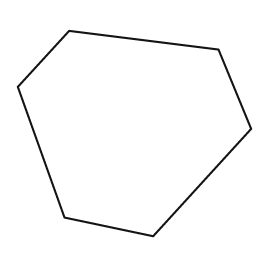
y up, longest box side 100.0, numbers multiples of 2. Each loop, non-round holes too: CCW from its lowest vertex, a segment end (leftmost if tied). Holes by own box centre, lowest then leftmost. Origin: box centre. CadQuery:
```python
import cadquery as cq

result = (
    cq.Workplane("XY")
    .moveTo(8.0, -44.0)
    .lineTo(50.0, 2.0)
    .lineTo(36.0, 36.0)
    .lineTo(-28.0, 44.0)
    .lineTo(-50.0, 20.0)
    .lineTo(-30.0, -36.0)
    .close()
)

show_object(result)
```